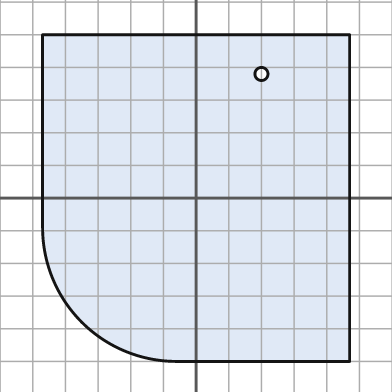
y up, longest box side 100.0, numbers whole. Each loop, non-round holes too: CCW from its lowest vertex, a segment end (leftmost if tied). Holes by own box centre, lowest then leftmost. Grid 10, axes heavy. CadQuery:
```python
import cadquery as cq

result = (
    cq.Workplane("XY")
    .moveTo(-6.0, -50.0)
    .lineTo(47.0, -50.0)
    .lineTo(47.0, 50.0)
    .lineTo(-47.0, 50.0)
    .lineTo(-47.0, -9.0)
    .threePointArc((-35.0, -38.0), (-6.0, -50.0))
    .close()
    .moveTo(20.0, 38.0)
    .circle(2.0)
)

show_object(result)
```